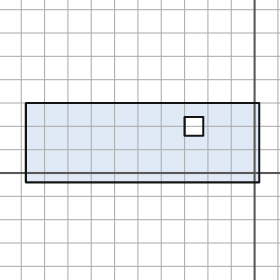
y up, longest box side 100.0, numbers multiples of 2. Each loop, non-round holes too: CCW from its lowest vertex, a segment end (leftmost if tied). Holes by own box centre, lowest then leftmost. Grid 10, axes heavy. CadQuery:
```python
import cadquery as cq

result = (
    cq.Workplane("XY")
    .moveTo(-98.0, -4.0)
    .lineTo(2.0, -4.0)
    .lineTo(2.0, 30.0)
    .lineTo(-98.0, 30.0)
    .close()
    .moveTo(-30.0, 16.0)
    .lineTo(-22.0, 16.0)
    .lineTo(-22.0, 24.0)
    .lineTo(-30.0, 24.0)
    .close()
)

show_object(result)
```